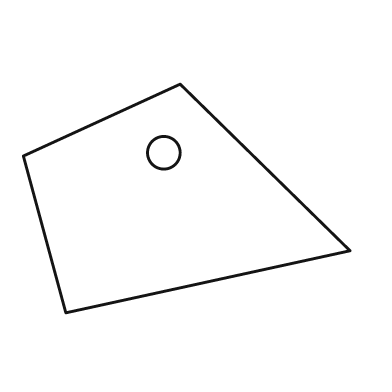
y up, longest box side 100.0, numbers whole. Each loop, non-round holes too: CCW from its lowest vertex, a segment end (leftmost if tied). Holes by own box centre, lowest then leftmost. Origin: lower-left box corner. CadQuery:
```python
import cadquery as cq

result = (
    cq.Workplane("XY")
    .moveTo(13.0, 0.0)
    .lineTo(100.0, 19.0)
    .lineTo(48.0, 70.0)
    .lineTo(0.0, 48.0)
    .close()
    .moveTo(43.0, 49.0)
    .circle(5.0)
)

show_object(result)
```